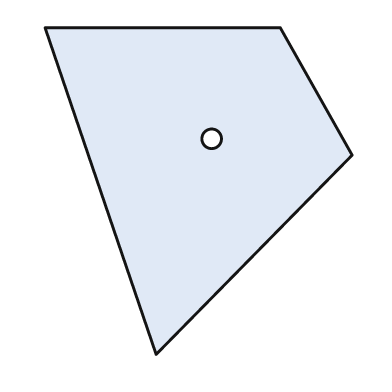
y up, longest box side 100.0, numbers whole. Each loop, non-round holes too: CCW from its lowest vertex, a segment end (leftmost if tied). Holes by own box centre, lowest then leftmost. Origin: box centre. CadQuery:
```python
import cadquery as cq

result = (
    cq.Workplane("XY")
    .moveTo(-13.0, -50.0)
    .lineTo(47.0, 11.0)
    .lineTo(25.0, 50.0)
    .lineTo(-47.0, 50.0)
    .close()
    .moveTo(4.0, 16.0)
    .circle(3.0)
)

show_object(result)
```